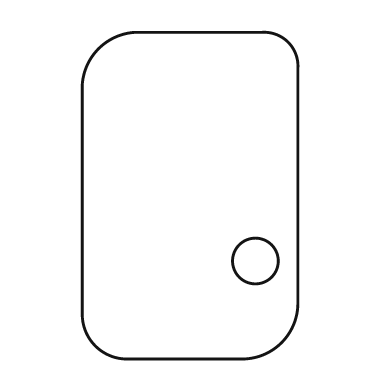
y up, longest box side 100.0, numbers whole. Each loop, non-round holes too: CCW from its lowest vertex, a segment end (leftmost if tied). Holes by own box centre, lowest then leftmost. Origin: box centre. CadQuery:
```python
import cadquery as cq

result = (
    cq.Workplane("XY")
    .moveTo(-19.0, -50.0)
    .lineTo(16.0, -50.0)
    .threePointArc((28.0, -45.0), (33.0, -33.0))
    .lineTo(33.0, 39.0)
    .threePointArc((30.0, 47.0), (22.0, 50.0))
    .lineTo(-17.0, 50.0)
    .threePointArc((-28.0, 45.0), (-33.0, 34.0))
    .lineTo(-33.0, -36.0)
    .threePointArc((-29.0, -46.0), (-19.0, -50.0))
    .close()
    .moveTo(20.0, -20.0)
    .circle(7.0)
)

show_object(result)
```